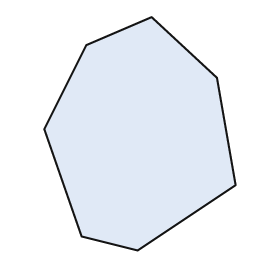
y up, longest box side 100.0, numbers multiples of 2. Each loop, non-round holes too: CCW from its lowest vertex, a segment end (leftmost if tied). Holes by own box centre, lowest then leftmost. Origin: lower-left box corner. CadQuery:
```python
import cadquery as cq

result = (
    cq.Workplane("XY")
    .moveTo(40.0, 0.0)
    .lineTo(82.0, 28.0)
    .lineTo(74.0, 74.0)
    .lineTo(46.0, 100.0)
    .lineTo(18.0, 88.0)
    .lineTo(0.0, 52.0)
    .lineTo(16.0, 6.0)
    .close()
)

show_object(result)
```